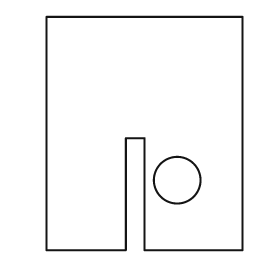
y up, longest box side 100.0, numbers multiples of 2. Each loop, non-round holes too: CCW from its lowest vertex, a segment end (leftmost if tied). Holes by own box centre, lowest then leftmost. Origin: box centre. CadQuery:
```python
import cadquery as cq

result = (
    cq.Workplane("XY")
    .moveTo(-42.0, -50.0)
    .lineTo(-8.0, -50.0)
    .lineTo(-8.0, -2.0)
    .lineTo(0.0, -2.0)
    .lineTo(0.0, -50.0)
    .lineTo(42.0, -50.0)
    .lineTo(42.0, 50.0)
    .lineTo(-42.0, 50.0)
    .close()
    .moveTo(14.0, -20.0)
    .circle(10.0)
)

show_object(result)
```